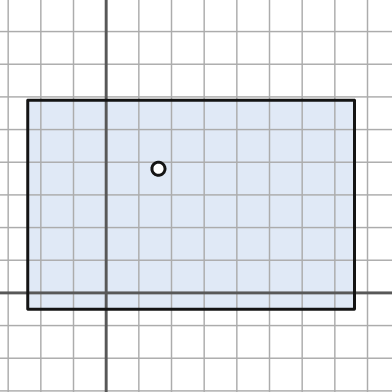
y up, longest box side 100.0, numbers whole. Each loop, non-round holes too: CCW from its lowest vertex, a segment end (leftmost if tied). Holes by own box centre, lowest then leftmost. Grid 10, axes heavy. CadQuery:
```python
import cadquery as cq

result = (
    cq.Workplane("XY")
    .moveTo(-24.0, -5.0)
    .lineTo(76.0, -5.0)
    .lineTo(76.0, 59.0)
    .lineTo(-24.0, 59.0)
    .close()
    .moveTo(16.0, 38.0)
    .circle(2.0)
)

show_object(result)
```